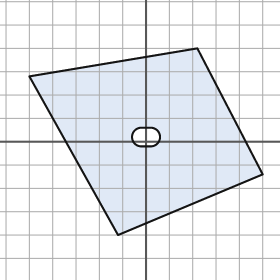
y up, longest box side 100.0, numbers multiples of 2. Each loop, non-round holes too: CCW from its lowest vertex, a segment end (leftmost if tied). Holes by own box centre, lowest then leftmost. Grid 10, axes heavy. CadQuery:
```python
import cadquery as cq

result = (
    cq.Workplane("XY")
    .moveTo(-12.0, -40.0)
    .lineTo(50.0, -14.0)
    .lineTo(22.0, 40.0)
    .lineTo(-50.0, 28.0)
    .close()
    .moveTo(-2.0, -2.0)
    .lineTo(2.0, -2.0)
    .threePointArc((6.0, 2.0), (2.0, 6.0))
    .lineTo(-2.0, 6.0)
    .threePointArc((-6.0, 2.0), (-2.0, -2.0))
    .close()
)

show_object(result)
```